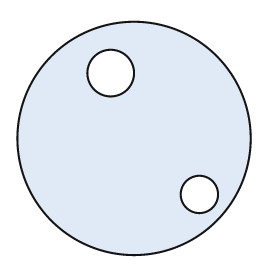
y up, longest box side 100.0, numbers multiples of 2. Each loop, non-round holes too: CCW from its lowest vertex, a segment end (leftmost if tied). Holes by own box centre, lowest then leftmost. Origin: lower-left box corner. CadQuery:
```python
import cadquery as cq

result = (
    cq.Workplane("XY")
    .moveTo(50.0, 50.0)
    .circle(50.0)
    .moveTo(78.0, 26.0)
    .circle(8.0)
    .moveTo(40.0, 78.0)
    .circle(10.0)
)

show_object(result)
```